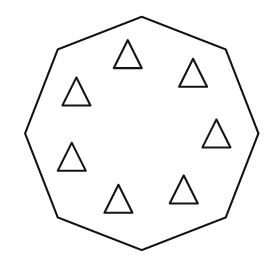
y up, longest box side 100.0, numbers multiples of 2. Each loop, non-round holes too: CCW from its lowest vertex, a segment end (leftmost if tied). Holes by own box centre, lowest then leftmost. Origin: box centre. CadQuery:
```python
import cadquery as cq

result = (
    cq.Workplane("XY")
    .moveTo(0.0, -50.0)
    .lineTo(36.0, -36.0)
    .lineTo(50.0, 0.0)
    .lineTo(36.0, 36.0)
    .lineTo(0.0, 50.0)
    .lineTo(-36.0, 36.0)
    .lineTo(-50.0, 0.0)
    .lineTo(-36.0, -36.0)
    .close()
    .moveTo(-16.0, -34.0)
    .lineTo(-4.0, -34.0)
    .lineTo(-10.0, -22.0)
    .close()
    .moveTo(12.0, -30.0)
    .lineTo(24.0, -30.0)
    .lineTo(18.0, -18.0)
    .close()
    .moveTo(-36.0, -16.0)
    .lineTo(-24.0, -16.0)
    .lineTo(-30.0, -4.0)
    .close()
    .moveTo(26.0, -6.0)
    .lineTo(38.0, -6.0)
    .lineTo(32.0, 6.0)
    .close()
    .moveTo(-34.0, 12.0)
    .lineTo(-22.0, 12.0)
    .lineTo(-28.0, 24.0)
    .close()
    .moveTo(16.0, 20.0)
    .lineTo(28.0, 20.0)
    .lineTo(22.0, 32.0)
    .close()
    .moveTo(-12.0, 28.0)
    .lineTo(0.0, 28.0)
    .lineTo(-6.0, 40.0)
    .close()
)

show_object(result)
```